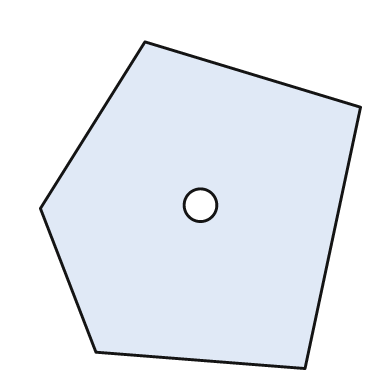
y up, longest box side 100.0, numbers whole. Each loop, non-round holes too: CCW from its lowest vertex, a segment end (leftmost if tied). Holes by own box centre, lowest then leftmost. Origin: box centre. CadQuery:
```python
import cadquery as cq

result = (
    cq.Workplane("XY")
    .moveTo(32.0, -50.0)
    .lineTo(49.0, 30.0)
    .lineTo(-17.0, 50.0)
    .lineTo(-49.0, -1.0)
    .lineTo(-32.0, -45.0)
    .close()
    .moveTo(0.0, 0.0)
    .circle(5.0)
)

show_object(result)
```